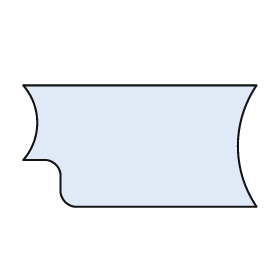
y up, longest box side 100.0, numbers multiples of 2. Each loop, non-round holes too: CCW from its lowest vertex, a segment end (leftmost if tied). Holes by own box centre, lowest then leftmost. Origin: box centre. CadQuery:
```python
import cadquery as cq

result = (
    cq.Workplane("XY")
    .moveTo(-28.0, -26.0)
    .lineTo(50.0, -26.0)
    .threePointArc((42.0, 0.0), (50.0, 26.0))
    .lineTo(-50.0, 26.0)
    .threePointArc((-44.0, 10.0), (-50.0, -6.0))
    .lineTo(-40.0, -6.0)
    .threePointArc((-36.0, -8.0), (-34.0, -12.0))
    .lineTo(-34.0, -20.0)
    .threePointArc((-32.0, -24.0), (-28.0, -26.0))
    .close()
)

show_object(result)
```